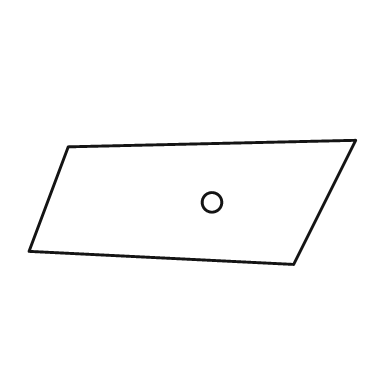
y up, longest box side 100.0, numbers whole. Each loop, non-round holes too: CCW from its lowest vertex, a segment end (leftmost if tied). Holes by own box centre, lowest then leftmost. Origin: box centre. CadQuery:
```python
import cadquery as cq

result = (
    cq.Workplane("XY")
    .moveTo(31.0, -19.0)
    .lineTo(50.0, 19.0)
    .lineTo(-38.0, 17.0)
    .lineTo(-50.0, -15.0)
    .close()
    .moveTo(6.0, 0.0)
    .circle(3.0)
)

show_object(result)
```